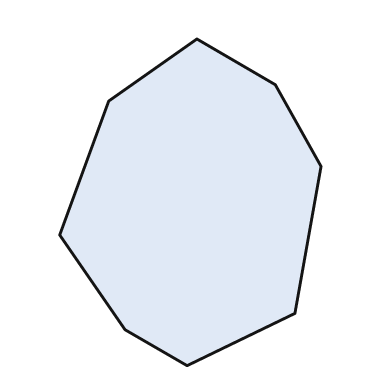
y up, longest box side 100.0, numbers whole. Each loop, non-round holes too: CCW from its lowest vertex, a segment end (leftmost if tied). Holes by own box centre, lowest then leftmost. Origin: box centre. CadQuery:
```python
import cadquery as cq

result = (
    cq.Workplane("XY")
    .moveTo(-1.0, -50.0)
    .lineTo(32.0, -34.0)
    .lineTo(40.0, 11.0)
    .lineTo(26.0, 36.0)
    .lineTo(2.0, 50.0)
    .lineTo(-25.0, 31.0)
    .lineTo(-40.0, -10.0)
    .lineTo(-20.0, -39.0)
    .close()
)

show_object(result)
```